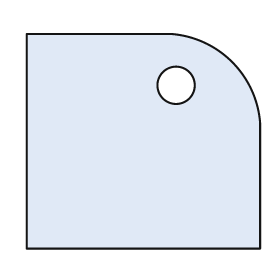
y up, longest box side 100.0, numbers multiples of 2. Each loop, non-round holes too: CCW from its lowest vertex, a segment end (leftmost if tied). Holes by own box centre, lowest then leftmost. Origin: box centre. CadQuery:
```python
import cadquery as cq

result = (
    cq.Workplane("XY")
    .moveTo(-50.0, -46.0)
    .lineTo(50.0, -46.0)
    .lineTo(50.0, 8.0)
    .threePointArc((38.0, 34.0), (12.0, 46.0))
    .lineTo(-50.0, 46.0)
    .close()
    .moveTo(14.0, 24.0)
    .circle(8.0)
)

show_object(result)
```